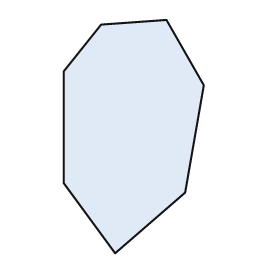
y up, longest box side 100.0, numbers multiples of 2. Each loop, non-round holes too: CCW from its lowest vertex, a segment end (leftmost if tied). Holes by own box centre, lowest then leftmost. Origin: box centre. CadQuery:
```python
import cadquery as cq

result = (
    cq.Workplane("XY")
    .moveTo(-8.0, -50.0)
    .lineTo(22.0, -24.0)
    .lineTo(30.0, 22.0)
    .lineTo(14.0, 50.0)
    .lineTo(-14.0, 48.0)
    .lineTo(-30.0, 28.0)
    .lineTo(-30.0, -20.0)
    .close()
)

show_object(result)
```